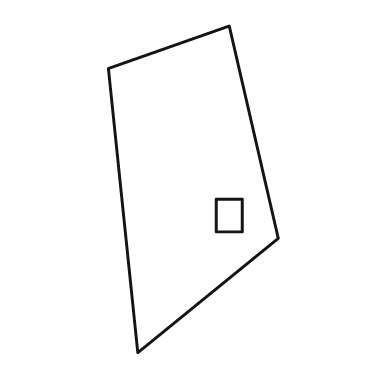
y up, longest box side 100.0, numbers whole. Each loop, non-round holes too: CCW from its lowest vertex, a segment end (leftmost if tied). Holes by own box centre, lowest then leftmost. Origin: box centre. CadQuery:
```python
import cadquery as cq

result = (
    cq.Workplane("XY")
    .moveTo(-17.0, -50.0)
    .lineTo(26.0, -15.0)
    .lineTo(11.0, 50.0)
    .lineTo(-26.0, 37.0)
    .close()
    .moveTo(7.0, -13.0)
    .lineTo(15.0, -13.0)
    .lineTo(15.0, -3.0)
    .lineTo(7.0, -3.0)
    .close()
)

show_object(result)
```